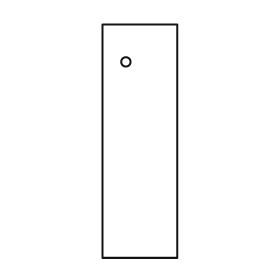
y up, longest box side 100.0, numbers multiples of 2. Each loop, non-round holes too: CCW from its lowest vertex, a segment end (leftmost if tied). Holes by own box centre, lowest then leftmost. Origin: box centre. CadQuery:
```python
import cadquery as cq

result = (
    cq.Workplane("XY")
    .moveTo(-16.0, -50.0)
    .lineTo(16.0, -50.0)
    .lineTo(16.0, 50.0)
    .lineTo(-16.0, 50.0)
    .close()
    .moveTo(-6.0, 34.0)
    .circle(2.0)
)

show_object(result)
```